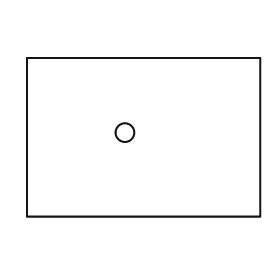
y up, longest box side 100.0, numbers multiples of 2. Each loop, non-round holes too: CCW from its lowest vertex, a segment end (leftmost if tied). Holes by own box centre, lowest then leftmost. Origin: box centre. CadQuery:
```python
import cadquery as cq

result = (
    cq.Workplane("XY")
    .moveTo(-50.0, -34.0)
    .lineTo(50.0, -34.0)
    .lineTo(50.0, 34.0)
    .lineTo(-50.0, 34.0)
    .close()
    .moveTo(-8.0, 2.0)
    .circle(4.0)
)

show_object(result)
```